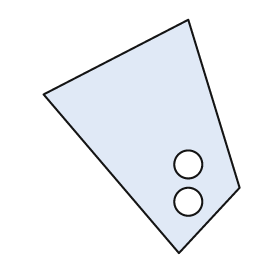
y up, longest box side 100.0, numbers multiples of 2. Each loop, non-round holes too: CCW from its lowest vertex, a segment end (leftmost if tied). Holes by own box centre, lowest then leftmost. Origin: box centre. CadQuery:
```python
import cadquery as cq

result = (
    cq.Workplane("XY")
    .moveTo(16.0, -50.0)
    .lineTo(42.0, -22.0)
    .lineTo(20.0, 50.0)
    .lineTo(-42.0, 18.0)
    .close()
    .moveTo(20.0, -28.0)
    .circle(6.0)
    .moveTo(20.0, -12.0)
    .circle(6.0)
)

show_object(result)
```